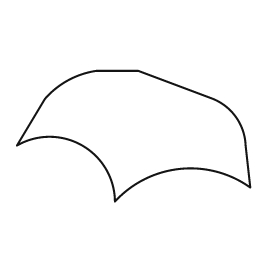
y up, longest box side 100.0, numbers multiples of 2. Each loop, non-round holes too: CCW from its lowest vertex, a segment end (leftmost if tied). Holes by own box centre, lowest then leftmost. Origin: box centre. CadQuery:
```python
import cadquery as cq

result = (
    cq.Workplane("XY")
    .moveTo(-8.0, -28.0)
    .threePointArc((20.0, -14.0), (50.0, -22.0))
    .lineTo(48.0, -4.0)
    .threePointArc((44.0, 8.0), (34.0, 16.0))
    .lineTo(2.0, 28.0)
    .lineTo(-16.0, 28.0)
    .threePointArc((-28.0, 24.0), (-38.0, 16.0))
    .lineTo(-50.0, -4.0)
    .threePointArc((-22.0, -4.0), (-8.0, -28.0))
    .close()
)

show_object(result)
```